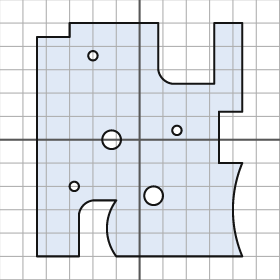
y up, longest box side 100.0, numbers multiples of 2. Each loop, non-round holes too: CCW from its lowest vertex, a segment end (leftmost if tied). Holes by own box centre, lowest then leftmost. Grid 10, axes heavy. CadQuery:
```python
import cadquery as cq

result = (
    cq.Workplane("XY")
    .moveTo(-44.0, -50.0)
    .lineTo(-26.0, -50.0)
    .lineTo(-26.0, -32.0)
    .threePointArc((-24.0, -28.0), (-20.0, -26.0))
    .lineTo(-10.0, -26.0)
    .threePointArc((-14.0, -38.0), (-10.0, -50.0))
    .lineTo(44.0, -50.0)
    .threePointArc((40.0, -30.0), (44.0, -10.0))
    .lineTo(34.0, -10.0)
    .lineTo(34.0, 12.0)
    .lineTo(44.0, 12.0)
    .lineTo(44.0, 50.0)
    .lineTo(32.0, 50.0)
    .lineTo(32.0, 24.0)
    .lineTo(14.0, 24.0)
    .threePointArc((10.0, 26.0), (8.0, 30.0))
    .lineTo(8.0, 50.0)
    .lineTo(-30.0, 50.0)
    .lineTo(-30.0, 44.0)
    .lineTo(-44.0, 44.0)
    .close()
    .moveTo(6.0, -24.0)
    .circle(4.0)
    .moveTo(-28.0, -20.0)
    .circle(2.0)
    .moveTo(-12.0, 0.0)
    .circle(4.0)
    .moveTo(16.0, 4.0)
    .circle(2.0)
    .moveTo(-20.0, 36.0)
    .circle(2.0)
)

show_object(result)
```